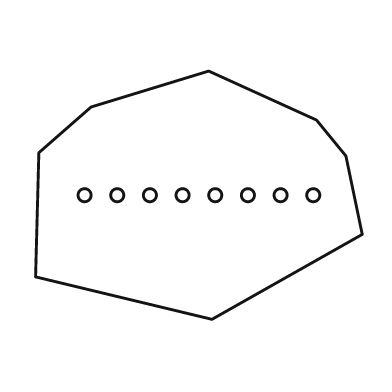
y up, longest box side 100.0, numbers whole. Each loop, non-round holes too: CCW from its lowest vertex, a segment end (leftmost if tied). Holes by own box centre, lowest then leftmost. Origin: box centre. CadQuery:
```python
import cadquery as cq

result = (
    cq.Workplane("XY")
    .moveTo(4.0, -38.0)
    .lineTo(50.0, -12.0)
    .lineTo(45.0, 12.0)
    .lineTo(36.0, 23.0)
    .lineTo(3.0, 38.0)
    .lineTo(-33.0, 27.0)
    .lineTo(-49.0, 13.0)
    .lineTo(-50.0, -25.0)
    .close()
    .moveTo(-35.0, 0.0)
    .circle(2.0)
    .moveTo(-25.0, 0.0)
    .circle(2.0)
    .moveTo(-15.0, 0.0)
    .circle(2.0)
    .moveTo(-5.0, 0.0)
    .circle(2.0)
    .moveTo(5.0, 0.0)
    .circle(2.0)
    .moveTo(15.0, 0.0)
    .circle(2.0)
    .moveTo(25.0, 0.0)
    .circle(2.0)
    .moveTo(35.0, 0.0)
    .circle(2.0)
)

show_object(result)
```